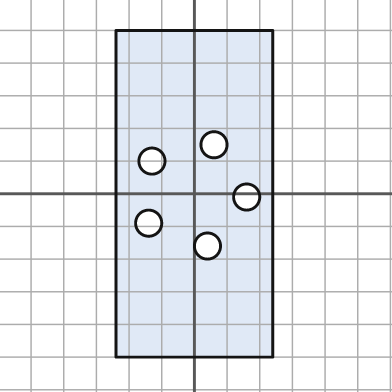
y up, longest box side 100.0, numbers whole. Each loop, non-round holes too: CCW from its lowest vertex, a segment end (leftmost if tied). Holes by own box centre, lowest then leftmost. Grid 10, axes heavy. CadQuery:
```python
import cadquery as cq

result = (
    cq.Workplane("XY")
    .moveTo(-24.0, -50.0)
    .lineTo(24.0, -50.0)
    .lineTo(24.0, 50.0)
    .lineTo(-24.0, 50.0)
    .close()
    .moveTo(4.0, -16.0)
    .circle(4.0)
    .moveTo(-14.0, -9.0)
    .circle(4.0)
    .moveTo(16.0, -1.0)
    .circle(4.0)
    .moveTo(-13.0, 10.0)
    .circle(4.0)
    .moveTo(6.0, 15.0)
    .circle(4.0)
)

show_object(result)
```